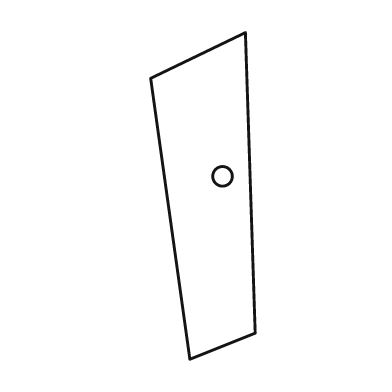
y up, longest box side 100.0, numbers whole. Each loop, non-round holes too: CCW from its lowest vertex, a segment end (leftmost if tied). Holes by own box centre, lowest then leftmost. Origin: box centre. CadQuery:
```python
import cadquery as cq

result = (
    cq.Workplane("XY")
    .moveTo(-4.0, -50.0)
    .lineTo(16.0, -42.0)
    .lineTo(13.0, 50.0)
    .lineTo(-16.0, 36.0)
    .close()
    .moveTo(6.0, 6.0)
    .circle(3.0)
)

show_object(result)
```